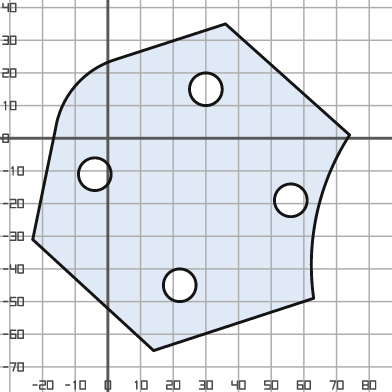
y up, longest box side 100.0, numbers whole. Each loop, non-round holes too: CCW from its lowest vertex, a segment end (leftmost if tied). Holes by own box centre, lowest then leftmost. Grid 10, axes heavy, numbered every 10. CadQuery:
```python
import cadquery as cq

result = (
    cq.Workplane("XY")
    .moveTo(14.0, -65.0)
    .lineTo(63.0, -49.0)
    .threePointArc((64.0, -23.0), (74.0, 1.0))
    .lineTo(36.0, 35.0)
    .lineTo(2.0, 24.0)
    .threePointArc((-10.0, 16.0), (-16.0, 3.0))
    .lineTo(-23.0, -31.0)
    .close()
    .moveTo(22.0, -45.0)
    .circle(5.0)
    .moveTo(56.0, -19.0)
    .circle(5.0)
    .moveTo(-4.0, -11.0)
    .circle(5.0)
    .moveTo(30.0, 15.0)
    .circle(5.0)
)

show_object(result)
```